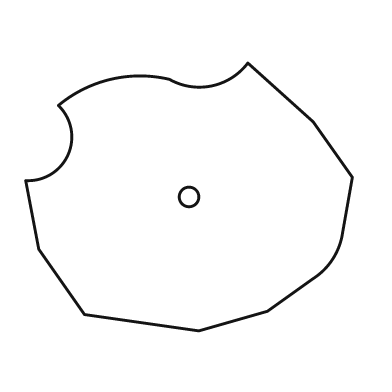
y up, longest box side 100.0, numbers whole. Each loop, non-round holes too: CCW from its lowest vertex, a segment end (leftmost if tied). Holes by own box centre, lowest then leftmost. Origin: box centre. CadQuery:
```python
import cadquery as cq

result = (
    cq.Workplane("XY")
    .moveTo(3.0, -41.0)
    .lineTo(24.0, -35.0)
    .lineTo(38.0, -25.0)
    .threePointArc((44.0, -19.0), (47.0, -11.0))
    .lineTo(50.0, 6.0)
    .lineTo(38.0, 23.0)
    .lineTo(18.0, 41.0)
    .threePointArc((7.0, 34.0), (-6.0, 36.0))
    .threePointArc((-24.0, 36.0), (-40.0, 28.0))
    .threePointArc((-37.0, 13.0), (-50.0, 5.0))
    .lineTo(-46.0, -16.0)
    .lineTo(-32.0, -36.0)
    .close()
    .moveTo(0.0, 0.0)
    .circle(3.0)
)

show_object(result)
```